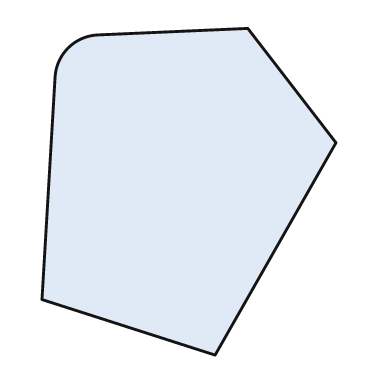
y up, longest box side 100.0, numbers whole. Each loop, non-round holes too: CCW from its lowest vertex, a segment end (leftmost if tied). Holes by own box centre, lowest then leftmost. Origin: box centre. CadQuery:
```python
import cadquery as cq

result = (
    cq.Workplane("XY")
    .moveTo(8.0, -50.0)
    .lineTo(45.0, 15.0)
    .lineTo(18.0, 50.0)
    .lineTo(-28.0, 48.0)
    .threePointArc((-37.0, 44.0), (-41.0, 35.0))
    .lineTo(-45.0, -33.0)
    .close()
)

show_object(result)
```